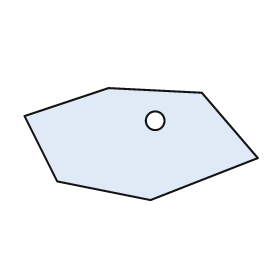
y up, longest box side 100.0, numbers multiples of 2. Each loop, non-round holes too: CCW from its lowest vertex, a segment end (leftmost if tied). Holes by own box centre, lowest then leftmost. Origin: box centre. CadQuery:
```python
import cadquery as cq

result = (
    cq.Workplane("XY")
    .moveTo(4.0, -24.0)
    .lineTo(50.0, -6.0)
    .lineTo(26.0, 22.0)
    .lineTo(-14.0, 24.0)
    .lineTo(-50.0, 12.0)
    .lineTo(-36.0, -16.0)
    .close()
    .moveTo(6.0, 10.0)
    .circle(4.0)
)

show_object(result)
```